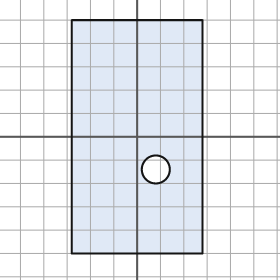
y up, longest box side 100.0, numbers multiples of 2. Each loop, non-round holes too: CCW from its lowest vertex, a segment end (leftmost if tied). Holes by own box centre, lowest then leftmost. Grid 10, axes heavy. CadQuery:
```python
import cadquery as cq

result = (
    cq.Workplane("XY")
    .moveTo(-28.0, -50.0)
    .lineTo(28.0, -50.0)
    .lineTo(28.0, 50.0)
    .lineTo(-28.0, 50.0)
    .close()
    .moveTo(8.0, -14.0)
    .circle(6.0)
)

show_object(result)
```